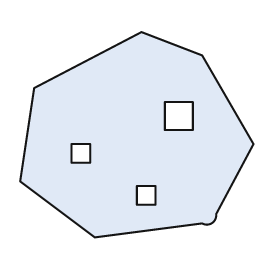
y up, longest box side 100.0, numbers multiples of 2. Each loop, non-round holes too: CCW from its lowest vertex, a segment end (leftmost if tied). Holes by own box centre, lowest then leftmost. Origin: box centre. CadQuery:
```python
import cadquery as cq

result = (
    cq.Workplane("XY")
    .moveTo(-18.0, -44.0)
    .lineTo(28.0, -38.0)
    .threePointArc((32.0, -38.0), (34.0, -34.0))
    .lineTo(50.0, -4.0)
    .lineTo(28.0, 34.0)
    .lineTo(2.0, 44.0)
    .lineTo(-44.0, 20.0)
    .lineTo(-50.0, -20.0)
    .close()
    .moveTo(0.0, -30.0)
    .lineTo(8.0, -30.0)
    .lineTo(8.0, -22.0)
    .lineTo(0.0, -22.0)
    .close()
    .moveTo(-28.0, -12.0)
    .lineTo(-20.0, -12.0)
    .lineTo(-20.0, -4.0)
    .lineTo(-28.0, -4.0)
    .close()
    .moveTo(12.0, 2.0)
    .lineTo(24.0, 2.0)
    .lineTo(24.0, 14.0)
    .lineTo(12.0, 14.0)
    .close()
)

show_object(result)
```